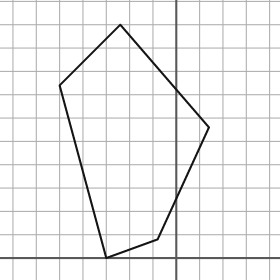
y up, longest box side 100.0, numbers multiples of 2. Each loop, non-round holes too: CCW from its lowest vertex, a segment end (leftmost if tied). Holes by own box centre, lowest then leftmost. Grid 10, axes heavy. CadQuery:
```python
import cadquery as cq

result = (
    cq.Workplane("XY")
    .moveTo(-30.0, 0.0)
    .lineTo(-8.0, 8.0)
    .lineTo(14.0, 56.0)
    .lineTo(-24.0, 100.0)
    .lineTo(-50.0, 74.0)
    .close()
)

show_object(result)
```